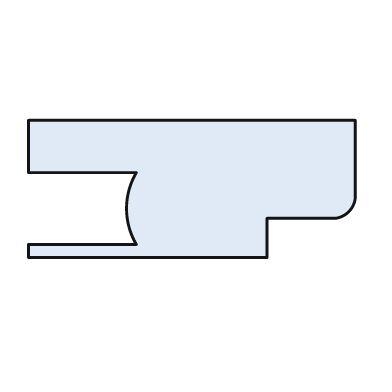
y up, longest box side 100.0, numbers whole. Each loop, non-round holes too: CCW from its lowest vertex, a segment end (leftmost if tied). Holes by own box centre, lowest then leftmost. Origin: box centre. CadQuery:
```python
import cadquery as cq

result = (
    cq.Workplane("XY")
    .moveTo(-50.0, -21.0)
    .lineTo(23.0, -21.0)
    .lineTo(23.0, -9.0)
    .lineTo(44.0, -9.0)
    .threePointArc((48.0, -7.0), (50.0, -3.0))
    .lineTo(50.0, 21.0)
    .lineTo(-50.0, 21.0)
    .lineTo(-50.0, 5.0)
    .lineTo(-17.0, 5.0)
    .threePointArc((-20.0, -6.0), (-17.0, -17.0))
    .lineTo(-50.0, -17.0)
    .close()
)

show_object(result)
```